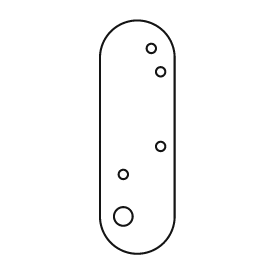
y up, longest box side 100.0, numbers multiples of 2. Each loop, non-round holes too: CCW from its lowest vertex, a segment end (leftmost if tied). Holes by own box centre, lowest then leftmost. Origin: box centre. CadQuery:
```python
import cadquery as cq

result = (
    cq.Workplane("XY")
    .moveTo(-16.0, -34.0)
    .threePointArc((0.0, -50.0), (16.0, -34.0))
    .lineTo(16.0, 34.0)
    .threePointArc((0.0, 50.0), (-16.0, 34.0))
    .close()
    .moveTo(-6.0, -34.0)
    .circle(4.0)
    .moveTo(-6.0, -16.0)
    .circle(2.0)
    .moveTo(10.0, -4.0)
    .circle(2.0)
    .moveTo(10.0, 28.0)
    .circle(2.0)
    .moveTo(6.0, 38.0)
    .circle(2.0)
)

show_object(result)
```